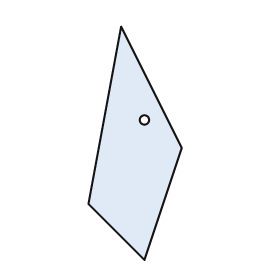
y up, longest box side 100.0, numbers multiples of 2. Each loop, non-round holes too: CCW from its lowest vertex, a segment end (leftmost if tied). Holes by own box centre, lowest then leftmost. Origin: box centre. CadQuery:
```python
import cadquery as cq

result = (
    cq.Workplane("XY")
    .moveTo(4.0, -50.0)
    .lineTo(20.0, -2.0)
    .lineTo(-6.0, 50.0)
    .lineTo(-20.0, -26.0)
    .close()
    .moveTo(4.0, 10.0)
    .circle(2.0)
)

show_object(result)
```